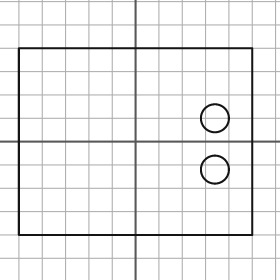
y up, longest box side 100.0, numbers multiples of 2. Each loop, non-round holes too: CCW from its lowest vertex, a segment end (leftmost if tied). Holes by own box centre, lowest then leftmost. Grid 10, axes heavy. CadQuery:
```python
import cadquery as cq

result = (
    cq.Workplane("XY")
    .moveTo(-50.0, -40.0)
    .lineTo(50.0, -40.0)
    .lineTo(50.0, 40.0)
    .lineTo(-50.0, 40.0)
    .close()
    .moveTo(34.0, -12.0)
    .circle(6.0)
    .moveTo(34.0, 10.0)
    .circle(6.0)
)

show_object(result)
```